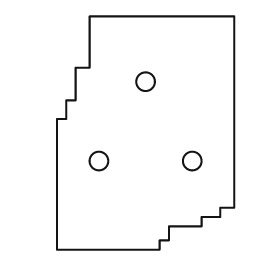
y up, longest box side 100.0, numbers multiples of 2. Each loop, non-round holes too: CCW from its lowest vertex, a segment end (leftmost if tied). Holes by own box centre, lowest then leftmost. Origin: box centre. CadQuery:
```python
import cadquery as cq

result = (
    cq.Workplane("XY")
    .moveTo(-38.0, -50.0)
    .lineTo(6.0, -50.0)
    .lineTo(6.0, -46.0)
    .lineTo(10.0, -46.0)
    .lineTo(10.0, -40.0)
    .lineTo(24.0, -40.0)
    .lineTo(24.0, -36.0)
    .lineTo(32.0, -36.0)
    .lineTo(32.0, -32.0)
    .lineTo(38.0, -32.0)
    .lineTo(38.0, 50.0)
    .lineTo(-24.0, 50.0)
    .lineTo(-24.0, 28.0)
    .lineTo(-30.0, 28.0)
    .lineTo(-30.0, 14.0)
    .lineTo(-34.0, 14.0)
    .lineTo(-34.0, 6.0)
    .lineTo(-38.0, 6.0)
    .close()
    .moveTo(-20.0, -12.0)
    .circle(4.0)
    .moveTo(20.0, -12.0)
    .circle(4.0)
    .moveTo(0.0, 22.0)
    .circle(4.0)
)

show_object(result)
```